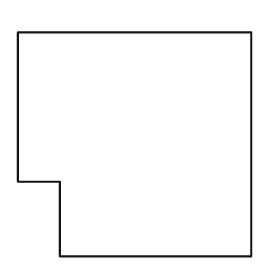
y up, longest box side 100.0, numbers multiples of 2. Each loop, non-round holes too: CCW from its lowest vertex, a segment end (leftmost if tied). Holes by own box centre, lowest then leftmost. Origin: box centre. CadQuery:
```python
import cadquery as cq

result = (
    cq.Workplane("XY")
    .moveTo(-32.0, -48.0)
    .lineTo(50.0, -48.0)
    .lineTo(50.0, 48.0)
    .lineTo(-50.0, 48.0)
    .lineTo(-50.0, -16.0)
    .lineTo(-32.0, -16.0)
    .close()
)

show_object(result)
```